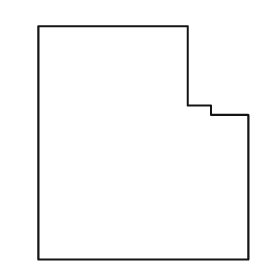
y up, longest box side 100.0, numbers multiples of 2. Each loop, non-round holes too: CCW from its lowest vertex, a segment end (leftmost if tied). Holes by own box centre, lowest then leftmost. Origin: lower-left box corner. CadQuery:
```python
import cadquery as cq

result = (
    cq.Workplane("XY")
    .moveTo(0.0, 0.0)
    .lineTo(90.0, 0.0)
    .lineTo(90.0, 62.0)
    .lineTo(74.0, 62.0)
    .lineTo(74.0, 66.0)
    .lineTo(64.0, 66.0)
    .lineTo(64.0, 100.0)
    .lineTo(0.0, 100.0)
    .close()
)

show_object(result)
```